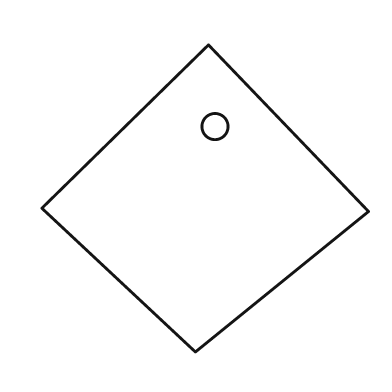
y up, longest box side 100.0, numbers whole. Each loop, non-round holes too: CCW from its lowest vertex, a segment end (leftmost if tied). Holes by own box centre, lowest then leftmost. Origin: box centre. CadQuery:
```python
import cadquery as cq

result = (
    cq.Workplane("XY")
    .moveTo(-3.0, -47.0)
    .lineTo(50.0, -4.0)
    .lineTo(1.0, 47.0)
    .lineTo(-50.0, -3.0)
    .close()
    .moveTo(3.0, 22.0)
    .circle(4.0)
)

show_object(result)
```